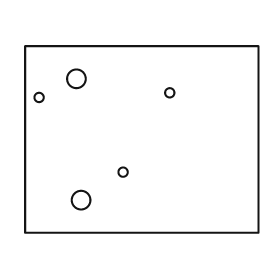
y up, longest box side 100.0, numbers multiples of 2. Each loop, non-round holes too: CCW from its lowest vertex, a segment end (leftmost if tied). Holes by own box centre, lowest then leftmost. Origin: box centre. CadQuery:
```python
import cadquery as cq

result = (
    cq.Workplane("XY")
    .moveTo(-50.0, -40.0)
    .lineTo(50.0, -40.0)
    .lineTo(50.0, 40.0)
    .lineTo(-50.0, 40.0)
    .close()
    .moveTo(-26.0, -26.0)
    .circle(4.0)
    .moveTo(-8.0, -14.0)
    .circle(2.0)
    .moveTo(-44.0, 18.0)
    .circle(2.0)
    .moveTo(12.0, 20.0)
    .circle(2.0)
    .moveTo(-28.0, 26.0)
    .circle(4.0)
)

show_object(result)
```